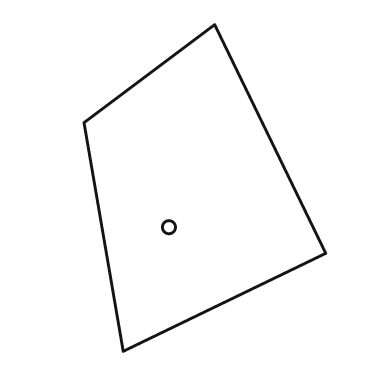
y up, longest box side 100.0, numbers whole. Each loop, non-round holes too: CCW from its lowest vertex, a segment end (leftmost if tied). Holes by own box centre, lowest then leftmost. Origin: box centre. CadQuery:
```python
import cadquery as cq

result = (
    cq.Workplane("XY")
    .moveTo(-25.0, -50.0)
    .lineTo(37.0, -20.0)
    .lineTo(3.0, 50.0)
    .lineTo(-37.0, 20.0)
    .close()
    .moveTo(-11.0, -12.0)
    .circle(2.0)
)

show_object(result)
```